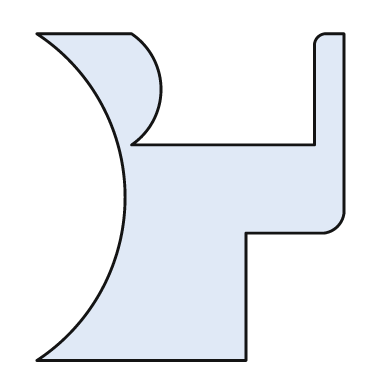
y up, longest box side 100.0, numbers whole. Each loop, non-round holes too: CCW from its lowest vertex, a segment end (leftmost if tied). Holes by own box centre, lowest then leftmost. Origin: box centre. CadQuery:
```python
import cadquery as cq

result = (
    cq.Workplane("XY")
    .moveTo(-47.0, -50.0)
    .lineTo(17.0, -50.0)
    .lineTo(17.0, -11.0)
    .lineTo(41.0, -11.0)
    .threePointArc((45.0, -9.0), (47.0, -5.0))
    .lineTo(47.0, 50.0)
    .lineTo(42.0, 50.0)
    .threePointArc((39.0, 49.0), (38.0, 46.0))
    .lineTo(38.0, 16.0)
    .lineTo(-18.0, 16.0)
    .threePointArc((-9.0, 33.0), (-18.0, 50.0))
    .lineTo(-47.0, 50.0)
    .threePointArc((-20.0, 0.0), (-47.0, -50.0))
    .close()
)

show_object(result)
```